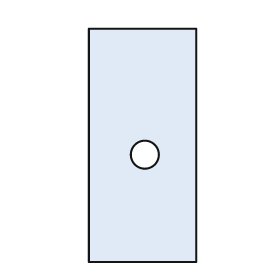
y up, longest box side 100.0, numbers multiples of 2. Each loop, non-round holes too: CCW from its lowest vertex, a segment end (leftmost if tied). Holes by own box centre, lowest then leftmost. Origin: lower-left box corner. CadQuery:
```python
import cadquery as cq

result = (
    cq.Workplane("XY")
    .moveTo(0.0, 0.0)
    .lineTo(46.0, 0.0)
    .lineTo(46.0, 100.0)
    .lineTo(0.0, 100.0)
    .close()
    .moveTo(24.0, 46.0)
    .circle(6.0)
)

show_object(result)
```